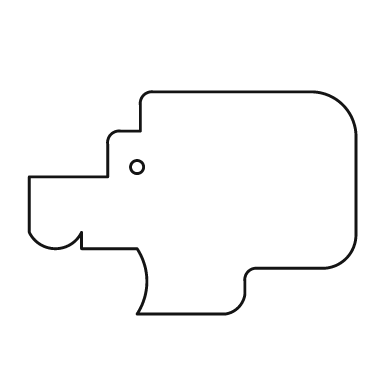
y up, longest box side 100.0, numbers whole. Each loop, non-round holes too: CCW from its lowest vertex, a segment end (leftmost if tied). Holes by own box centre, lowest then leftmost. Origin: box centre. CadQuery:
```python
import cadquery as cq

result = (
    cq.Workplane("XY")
    .moveTo(-17.0, -34.0)
    .lineTo(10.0, -34.0)
    .threePointArc((14.0, -32.0), (16.0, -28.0))
    .lineTo(16.0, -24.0)
    .threePointArc((17.0, -21.0), (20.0, -20.0))
    .lineTo(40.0, -20.0)
    .threePointArc((47.0, -17.0), (50.0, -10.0))
    .lineTo(50.0, 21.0)
    .threePointArc((46.0, 30.0), (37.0, 34.0))
    .lineTo(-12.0, 34.0)
    .threePointArc((-15.0, 33.0), (-16.0, 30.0))
    .lineTo(-16.0, 22.0)
    .lineTo(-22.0, 22.0)
    .threePointArc((-25.0, 21.0), (-26.0, 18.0))
    .lineTo(-26.0, 8.0)
    .lineTo(-50.0, 8.0)
    .lineTo(-50.0, -9.0)
    .threePointArc((-42.0, -14.0), (-34.0, -9.0))
    .lineTo(-34.0, -14.0)
    .lineTo(-17.0, -14.0)
    .threePointArc((-14.0, -24.0), (-17.0, -34.0))
    .close()
    .moveTo(-17.0, 11.0)
    .circle(2.0)
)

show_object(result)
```